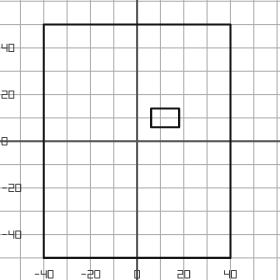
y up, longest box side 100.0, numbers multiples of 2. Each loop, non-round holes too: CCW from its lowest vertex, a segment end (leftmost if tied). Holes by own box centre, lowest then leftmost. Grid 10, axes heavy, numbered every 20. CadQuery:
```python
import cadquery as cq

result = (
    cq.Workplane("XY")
    .moveTo(-40.0, -50.0)
    .lineTo(40.0, -50.0)
    .lineTo(40.0, 50.0)
    .lineTo(-40.0, 50.0)
    .close()
    .moveTo(6.0, 6.0)
    .lineTo(18.0, 6.0)
    .lineTo(18.0, 14.0)
    .lineTo(6.0, 14.0)
    .close()
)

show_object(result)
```